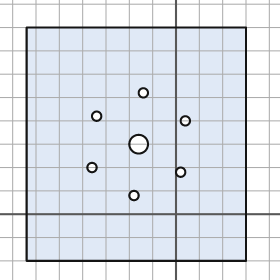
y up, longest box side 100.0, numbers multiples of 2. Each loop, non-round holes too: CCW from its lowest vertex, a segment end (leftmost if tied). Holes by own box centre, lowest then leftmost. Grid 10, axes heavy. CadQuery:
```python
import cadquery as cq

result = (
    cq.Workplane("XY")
    .moveTo(-64.0, -20.0)
    .lineTo(30.0, -20.0)
    .lineTo(30.0, 80.0)
    .lineTo(-64.0, 80.0)
    .close()
    .moveTo(-18.0, 8.0)
    .circle(2.0)
    .moveTo(2.0, 18.0)
    .circle(2.0)
    .moveTo(-36.0, 20.0)
    .circle(2.0)
    .moveTo(-16.0, 30.0)
    .circle(4.0)
    .moveTo(4.0, 40.0)
    .circle(2.0)
    .moveTo(-34.0, 42.0)
    .circle(2.0)
    .moveTo(-14.0, 52.0)
    .circle(2.0)
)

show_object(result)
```